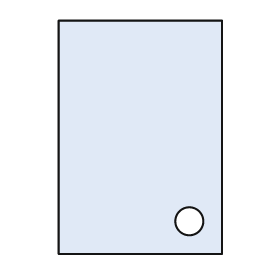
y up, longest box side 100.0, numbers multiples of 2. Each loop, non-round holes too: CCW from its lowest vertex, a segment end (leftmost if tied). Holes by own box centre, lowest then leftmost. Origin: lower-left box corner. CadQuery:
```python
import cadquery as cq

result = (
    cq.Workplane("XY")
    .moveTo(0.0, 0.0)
    .lineTo(70.0, 0.0)
    .lineTo(70.0, 100.0)
    .lineTo(0.0, 100.0)
    .close()
    .moveTo(56.0, 14.0)
    .circle(6.0)
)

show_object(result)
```